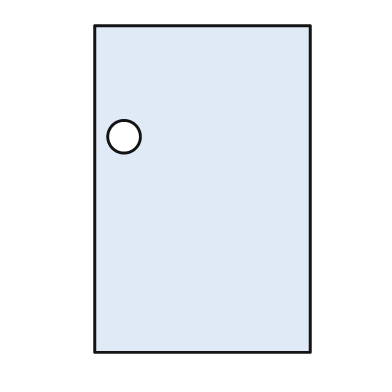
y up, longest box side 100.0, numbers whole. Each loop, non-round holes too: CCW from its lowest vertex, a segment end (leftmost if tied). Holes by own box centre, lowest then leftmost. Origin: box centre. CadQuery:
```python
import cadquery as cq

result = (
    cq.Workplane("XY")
    .moveTo(-33.0, -50.0)
    .lineTo(33.0, -50.0)
    .lineTo(33.0, 50.0)
    .lineTo(-33.0, 50.0)
    .close()
    .moveTo(-24.0, 16.0)
    .circle(5.0)
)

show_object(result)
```